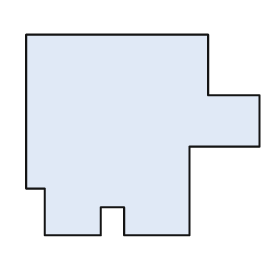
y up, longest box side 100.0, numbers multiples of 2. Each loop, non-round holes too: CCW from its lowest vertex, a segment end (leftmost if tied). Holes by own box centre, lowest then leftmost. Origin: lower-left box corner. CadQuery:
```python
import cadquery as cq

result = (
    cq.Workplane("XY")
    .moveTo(8.0, 0.0)
    .lineTo(32.0, 0.0)
    .lineTo(32.0, 12.0)
    .lineTo(42.0, 12.0)
    .lineTo(42.0, 0.0)
    .lineTo(70.0, 0.0)
    .lineTo(70.0, 38.0)
    .lineTo(100.0, 38.0)
    .lineTo(100.0, 60.0)
    .lineTo(78.0, 60.0)
    .lineTo(78.0, 86.0)
    .lineTo(0.0, 86.0)
    .lineTo(0.0, 20.0)
    .lineTo(8.0, 20.0)
    .close()
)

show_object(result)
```